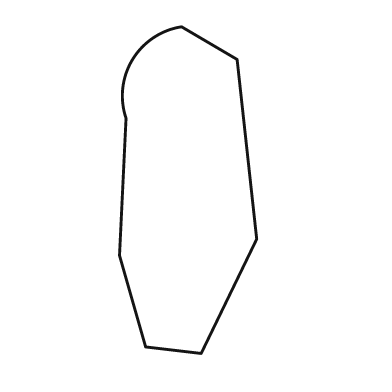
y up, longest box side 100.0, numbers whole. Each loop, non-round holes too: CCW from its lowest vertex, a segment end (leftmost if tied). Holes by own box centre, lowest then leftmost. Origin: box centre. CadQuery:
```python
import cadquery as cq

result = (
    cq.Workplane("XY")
    .moveTo(4.0, -50.0)
    .lineTo(21.0, -15.0)
    .lineTo(15.0, 40.0)
    .lineTo(-2.0, 50.0)
    .threePointArc((-17.0, 40.0), (-19.0, 22.0))
    .lineTo(-21.0, -20.0)
    .lineTo(-13.0, -48.0)
    .close()
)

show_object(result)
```